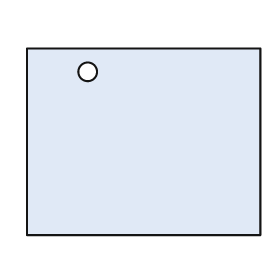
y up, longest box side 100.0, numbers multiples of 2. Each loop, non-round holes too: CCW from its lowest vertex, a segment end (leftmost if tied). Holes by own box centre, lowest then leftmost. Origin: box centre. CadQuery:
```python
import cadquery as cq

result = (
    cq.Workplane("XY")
    .moveTo(-50.0, -40.0)
    .lineTo(50.0, -40.0)
    .lineTo(50.0, 40.0)
    .lineTo(-50.0, 40.0)
    .close()
    .moveTo(-24.0, 30.0)
    .circle(4.0)
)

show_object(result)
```